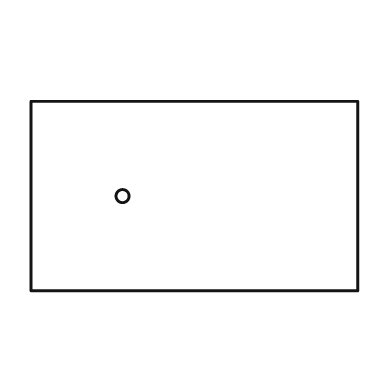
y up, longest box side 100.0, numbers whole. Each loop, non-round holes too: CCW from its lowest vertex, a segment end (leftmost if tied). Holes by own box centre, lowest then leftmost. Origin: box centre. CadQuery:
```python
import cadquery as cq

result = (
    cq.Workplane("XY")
    .moveTo(-50.0, -29.0)
    .lineTo(50.0, -29.0)
    .lineTo(50.0, 29.0)
    .lineTo(-50.0, 29.0)
    .close()
    .moveTo(-22.0, 0.0)
    .circle(2.0)
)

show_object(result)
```